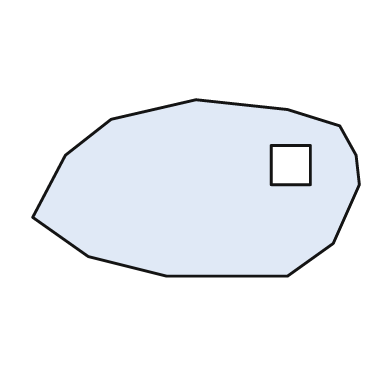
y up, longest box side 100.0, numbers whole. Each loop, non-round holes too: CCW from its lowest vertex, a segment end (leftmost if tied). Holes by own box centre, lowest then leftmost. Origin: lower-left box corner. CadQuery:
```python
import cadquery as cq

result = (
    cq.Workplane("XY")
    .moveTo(41.0, 0.0)
    .lineTo(78.0, 0.0)
    .lineTo(92.0, 10.0)
    .lineTo(100.0, 28.0)
    .lineTo(99.0, 37.0)
    .lineTo(94.0, 46.0)
    .lineTo(78.0, 51.0)
    .lineTo(50.0, 54.0)
    .lineTo(24.0, 48.0)
    .lineTo(10.0, 37.0)
    .lineTo(0.0, 18.0)
    .lineTo(17.0, 6.0)
    .close()
    .moveTo(73.0, 28.0)
    .lineTo(85.0, 28.0)
    .lineTo(85.0, 40.0)
    .lineTo(73.0, 40.0)
    .close()
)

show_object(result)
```